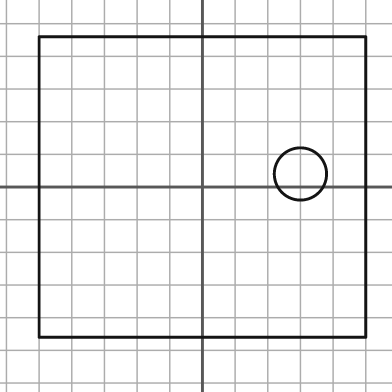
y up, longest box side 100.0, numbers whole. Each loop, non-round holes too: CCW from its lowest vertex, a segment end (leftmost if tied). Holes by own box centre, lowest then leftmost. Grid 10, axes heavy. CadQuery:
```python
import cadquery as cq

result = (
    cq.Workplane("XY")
    .moveTo(-50.0, -46.0)
    .lineTo(50.0, -46.0)
    .lineTo(50.0, 46.0)
    .lineTo(-50.0, 46.0)
    .close()
    .moveTo(30.0, 4.0)
    .circle(8.0)
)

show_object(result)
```